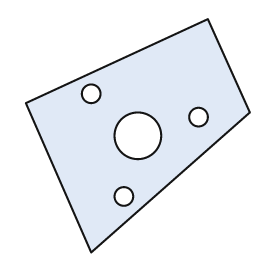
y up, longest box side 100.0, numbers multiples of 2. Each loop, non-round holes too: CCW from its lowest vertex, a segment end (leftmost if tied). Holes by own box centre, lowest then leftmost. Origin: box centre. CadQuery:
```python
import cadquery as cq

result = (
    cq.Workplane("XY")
    .moveTo(-20.0, -50.0)
    .lineTo(48.0, 10.0)
    .lineTo(30.0, 50.0)
    .lineTo(-48.0, 14.0)
    .close()
    .moveTo(-6.0, -26.0)
    .circle(4.0)
    .moveTo(0.0, 0.0)
    .circle(10.0)
    .moveTo(26.0, 8.0)
    .circle(4.0)
    .moveTo(-20.0, 18.0)
    .circle(4.0)
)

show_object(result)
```